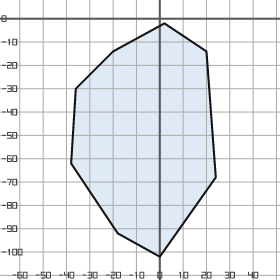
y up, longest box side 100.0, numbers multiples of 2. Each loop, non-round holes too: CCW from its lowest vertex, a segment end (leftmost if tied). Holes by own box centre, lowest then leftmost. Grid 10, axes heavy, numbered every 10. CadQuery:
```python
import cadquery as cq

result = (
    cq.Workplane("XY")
    .moveTo(0.0, -102.0)
    .lineTo(24.0, -68.0)
    .lineTo(20.0, -14.0)
    .lineTo(2.0, -2.0)
    .lineTo(-20.0, -14.0)
    .lineTo(-36.0, -30.0)
    .lineTo(-38.0, -62.0)
    .lineTo(-18.0, -92.0)
    .close()
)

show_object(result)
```